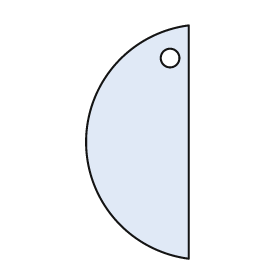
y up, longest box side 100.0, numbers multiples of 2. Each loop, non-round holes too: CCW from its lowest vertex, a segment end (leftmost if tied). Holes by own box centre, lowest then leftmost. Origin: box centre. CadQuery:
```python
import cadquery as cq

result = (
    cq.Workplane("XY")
    .moveTo(22.0, -50.0)
    .lineTo(22.0, 50.0)
    .threePointArc((-22.0, 0.0), (22.0, -50.0))
    .close()
    .moveTo(14.0, 36.0)
    .circle(4.0)
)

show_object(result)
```